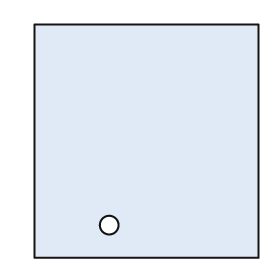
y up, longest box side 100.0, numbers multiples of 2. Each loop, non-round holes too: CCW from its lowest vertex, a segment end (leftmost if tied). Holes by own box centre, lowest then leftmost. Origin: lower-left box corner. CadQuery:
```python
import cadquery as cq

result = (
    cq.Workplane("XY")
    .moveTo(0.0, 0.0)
    .lineTo(96.0, 0.0)
    .lineTo(96.0, 100.0)
    .lineTo(0.0, 100.0)
    .close()
    .moveTo(32.0, 14.0)
    .circle(4.0)
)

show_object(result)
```